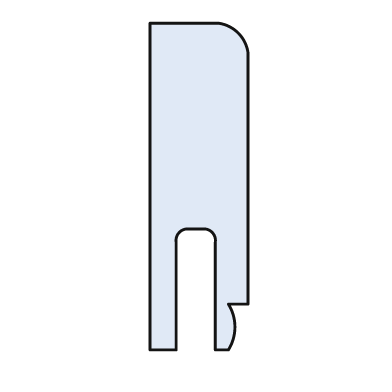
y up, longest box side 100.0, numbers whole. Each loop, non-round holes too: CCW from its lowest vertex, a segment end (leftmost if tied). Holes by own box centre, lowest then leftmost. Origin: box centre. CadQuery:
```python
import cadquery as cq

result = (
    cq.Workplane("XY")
    .moveTo(-15.0, -50.0)
    .lineTo(-7.0, -50.0)
    .lineTo(-7.0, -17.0)
    .threePointArc((-6.0, -14.0), (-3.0, -13.0))
    .lineTo(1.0, -13.0)
    .threePointArc((4.0, -14.0), (5.0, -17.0))
    .lineTo(5.0, -50.0)
    .lineTo(9.0, -50.0)
    .threePointArc((11.0, -43.0), (9.0, -36.0))
    .lineTo(15.0, -36.0)
    .lineTo(15.0, 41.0)
    .threePointArc((12.0, 47.0), (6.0, 50.0))
    .lineTo(-15.0, 50.0)
    .close()
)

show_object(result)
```